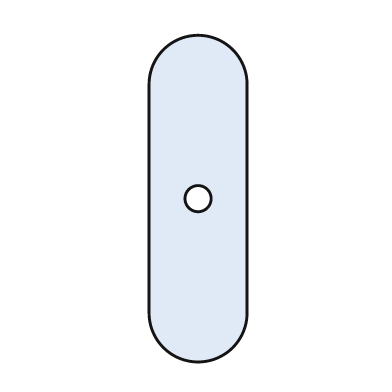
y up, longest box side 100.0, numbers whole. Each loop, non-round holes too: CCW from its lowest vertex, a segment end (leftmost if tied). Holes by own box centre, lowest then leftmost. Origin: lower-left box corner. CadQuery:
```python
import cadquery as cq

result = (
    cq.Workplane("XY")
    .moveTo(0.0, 15.0)
    .threePointArc((15.0, 0.0), (30.0, 15.0))
    .lineTo(30.0, 85.0)
    .threePointArc((15.0, 100.0), (0.0, 85.0))
    .close()
    .moveTo(15.0, 50.0)
    .circle(4.0)
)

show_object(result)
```